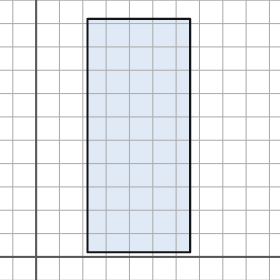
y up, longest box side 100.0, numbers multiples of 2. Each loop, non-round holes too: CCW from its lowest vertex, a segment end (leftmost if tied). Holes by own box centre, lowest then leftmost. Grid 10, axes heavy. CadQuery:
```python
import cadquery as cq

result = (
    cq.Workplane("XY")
    .moveTo(22.0, 2.0)
    .lineTo(66.0, 2.0)
    .lineTo(66.0, 102.0)
    .lineTo(22.0, 102.0)
    .close()
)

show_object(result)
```